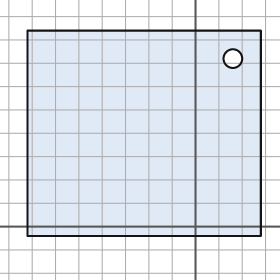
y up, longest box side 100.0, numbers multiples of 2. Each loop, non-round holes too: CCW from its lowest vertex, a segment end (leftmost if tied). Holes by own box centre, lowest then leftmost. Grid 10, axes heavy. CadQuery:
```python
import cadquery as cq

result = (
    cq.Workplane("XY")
    .moveTo(-72.0, -4.0)
    .lineTo(28.0, -4.0)
    .lineTo(28.0, 84.0)
    .lineTo(-72.0, 84.0)
    .close()
    .moveTo(16.0, 72.0)
    .circle(4.0)
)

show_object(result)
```